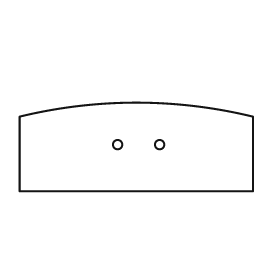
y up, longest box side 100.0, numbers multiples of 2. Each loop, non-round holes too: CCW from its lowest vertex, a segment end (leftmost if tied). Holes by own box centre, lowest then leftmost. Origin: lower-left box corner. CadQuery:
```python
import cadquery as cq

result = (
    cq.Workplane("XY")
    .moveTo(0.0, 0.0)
    .lineTo(100.0, 0.0)
    .lineTo(100.0, 32.0)
    .threePointArc((50.0, 38.0), (0.0, 32.0))
    .close()
    .moveTo(42.0, 20.0)
    .circle(2.0)
    .moveTo(60.0, 20.0)
    .circle(2.0)
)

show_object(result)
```